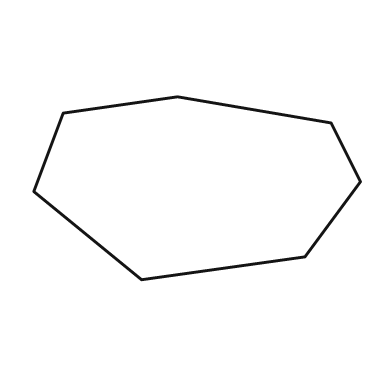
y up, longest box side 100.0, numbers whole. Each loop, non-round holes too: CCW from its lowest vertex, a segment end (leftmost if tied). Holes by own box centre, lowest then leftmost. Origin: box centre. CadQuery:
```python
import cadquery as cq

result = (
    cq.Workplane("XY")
    .moveTo(-17.0, -28.0)
    .lineTo(33.0, -21.0)
    .lineTo(50.0, 2.0)
    .lineTo(41.0, 20.0)
    .lineTo(-6.0, 28.0)
    .lineTo(-41.0, 23.0)
    .lineTo(-50.0, -1.0)
    .close()
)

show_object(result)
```